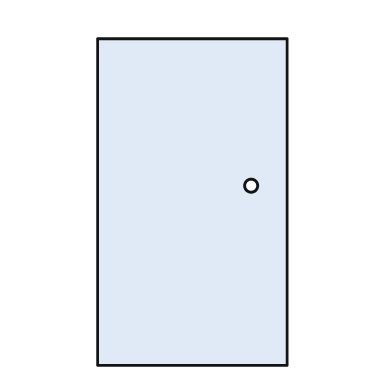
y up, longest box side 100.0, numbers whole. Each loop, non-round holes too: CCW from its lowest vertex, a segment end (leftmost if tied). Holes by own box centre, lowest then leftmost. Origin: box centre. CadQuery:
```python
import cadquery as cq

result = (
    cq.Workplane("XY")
    .moveTo(-29.0, -50.0)
    .lineTo(29.0, -50.0)
    .lineTo(29.0, 50.0)
    .lineTo(-29.0, 50.0)
    .close()
    .moveTo(18.0, 5.0)
    .circle(2.0)
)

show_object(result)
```